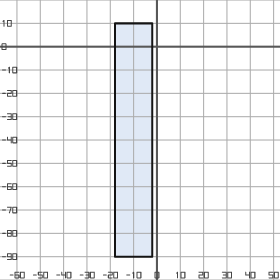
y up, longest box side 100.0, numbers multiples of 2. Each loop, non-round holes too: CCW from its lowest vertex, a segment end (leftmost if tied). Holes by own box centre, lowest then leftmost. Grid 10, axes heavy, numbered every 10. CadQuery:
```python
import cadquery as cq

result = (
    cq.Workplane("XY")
    .moveTo(-18.0, -90.0)
    .lineTo(-2.0, -90.0)
    .lineTo(-2.0, 10.0)
    .lineTo(-18.0, 10.0)
    .close()
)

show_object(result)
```